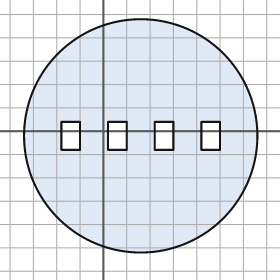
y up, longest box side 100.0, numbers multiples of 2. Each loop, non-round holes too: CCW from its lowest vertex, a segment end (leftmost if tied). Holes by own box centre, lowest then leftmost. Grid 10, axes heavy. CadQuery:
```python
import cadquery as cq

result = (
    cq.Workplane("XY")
    .moveTo(16.0, -2.0)
    .circle(50.0)
    .moveTo(-18.0, -8.0)
    .lineTo(-10.0, -8.0)
    .lineTo(-10.0, 4.0)
    .lineTo(-18.0, 4.0)
    .close()
    .moveTo(2.0, -8.0)
    .lineTo(10.0, -8.0)
    .lineTo(10.0, 4.0)
    .lineTo(2.0, 4.0)
    .close()
    .moveTo(22.0, -8.0)
    .lineTo(30.0, -8.0)
    .lineTo(30.0, 4.0)
    .lineTo(22.0, 4.0)
    .close()
    .moveTo(42.0, -8.0)
    .lineTo(50.0, -8.0)
    .lineTo(50.0, 4.0)
    .lineTo(42.0, 4.0)
    .close()
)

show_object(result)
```